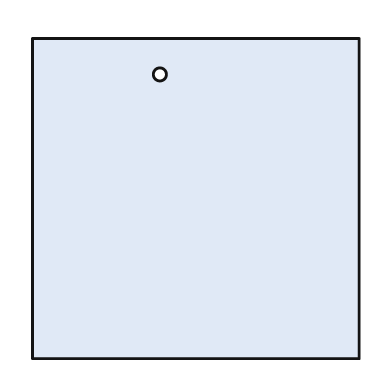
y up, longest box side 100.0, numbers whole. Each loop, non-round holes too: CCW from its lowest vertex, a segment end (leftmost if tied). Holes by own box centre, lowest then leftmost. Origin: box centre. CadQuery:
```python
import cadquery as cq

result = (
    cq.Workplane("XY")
    .moveTo(-50.0, -49.0)
    .lineTo(50.0, -49.0)
    .lineTo(50.0, 49.0)
    .lineTo(-50.0, 49.0)
    .close()
    .moveTo(-11.0, 38.0)
    .circle(2.0)
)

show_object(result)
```